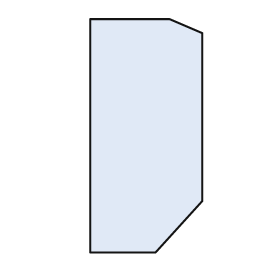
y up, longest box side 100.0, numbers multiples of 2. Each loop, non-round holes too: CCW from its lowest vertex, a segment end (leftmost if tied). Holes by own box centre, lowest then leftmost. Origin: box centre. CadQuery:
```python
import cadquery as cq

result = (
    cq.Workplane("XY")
    .moveTo(-24.0, -50.0)
    .lineTo(4.0, -50.0)
    .lineTo(24.0, -28.0)
    .lineTo(24.0, 44.0)
    .lineTo(10.0, 50.0)
    .lineTo(-24.0, 50.0)
    .close()
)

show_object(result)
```